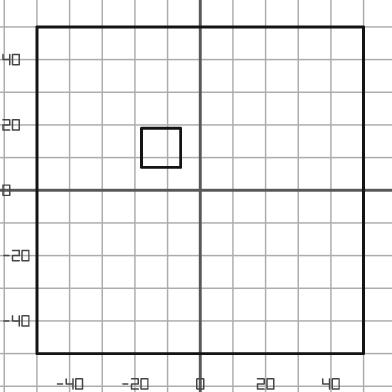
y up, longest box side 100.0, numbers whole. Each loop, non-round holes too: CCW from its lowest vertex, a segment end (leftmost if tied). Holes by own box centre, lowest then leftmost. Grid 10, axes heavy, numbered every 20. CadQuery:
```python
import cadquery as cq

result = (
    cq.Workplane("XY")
    .moveTo(-50.0, -50.0)
    .lineTo(50.0, -50.0)
    .lineTo(50.0, 50.0)
    .lineTo(-50.0, 50.0)
    .close()
    .moveTo(-18.0, 7.0)
    .lineTo(-6.0, 7.0)
    .lineTo(-6.0, 19.0)
    .lineTo(-18.0, 19.0)
    .close()
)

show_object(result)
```